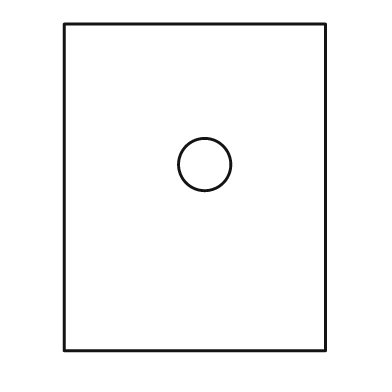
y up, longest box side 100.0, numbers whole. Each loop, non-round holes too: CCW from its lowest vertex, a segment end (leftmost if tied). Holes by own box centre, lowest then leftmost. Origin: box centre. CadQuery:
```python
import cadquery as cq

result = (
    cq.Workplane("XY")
    .moveTo(-40.0, -50.0)
    .lineTo(40.0, -50.0)
    .lineTo(40.0, 50.0)
    .lineTo(-40.0, 50.0)
    .close()
    .moveTo(3.0, 7.0)
    .circle(8.0)
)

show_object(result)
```